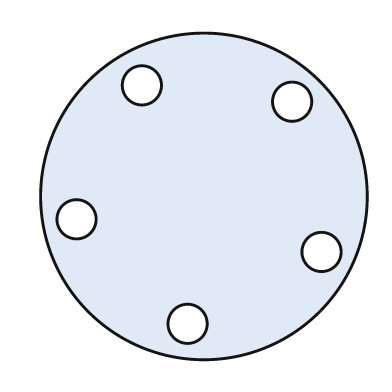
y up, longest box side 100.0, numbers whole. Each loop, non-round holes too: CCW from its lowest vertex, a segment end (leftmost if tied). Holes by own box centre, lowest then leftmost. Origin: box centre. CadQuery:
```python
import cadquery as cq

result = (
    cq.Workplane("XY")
    .moveTo(0.0, 0.0)
    .circle(50.0)
    .moveTo(-5.0, -39.0)
    .circle(6.0)
    .moveTo(36.0, -17.0)
    .circle(6.0)
    .moveTo(-39.0, -7.0)
    .circle(6.0)
    .moveTo(27.0, 29.0)
    .circle(6.0)
    .moveTo(-19.0, 34.0)
    .circle(6.0)
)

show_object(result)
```